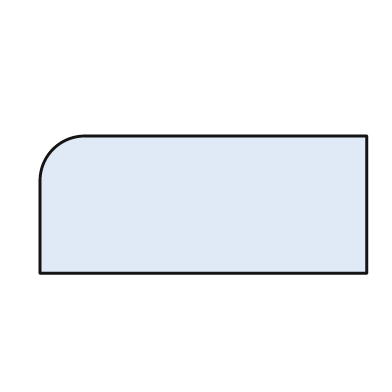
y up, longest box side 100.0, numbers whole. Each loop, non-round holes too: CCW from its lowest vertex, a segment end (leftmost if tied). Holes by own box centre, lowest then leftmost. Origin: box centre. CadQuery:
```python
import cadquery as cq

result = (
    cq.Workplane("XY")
    .moveTo(-50.0, -21.0)
    .lineTo(50.0, -21.0)
    .lineTo(50.0, 21.0)
    .lineTo(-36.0, 21.0)
    .threePointArc((-46.0, 17.0), (-50.0, 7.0))
    .close()
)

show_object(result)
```